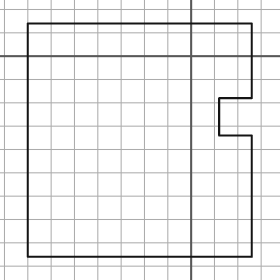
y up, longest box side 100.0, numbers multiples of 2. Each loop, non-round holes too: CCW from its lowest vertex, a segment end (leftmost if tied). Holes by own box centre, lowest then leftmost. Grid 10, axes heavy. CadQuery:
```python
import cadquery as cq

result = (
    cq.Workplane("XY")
    .moveTo(-70.0, -86.0)
    .lineTo(26.0, -86.0)
    .lineTo(26.0, -34.0)
    .lineTo(12.0, -34.0)
    .lineTo(12.0, -18.0)
    .lineTo(26.0, -18.0)
    .lineTo(26.0, 14.0)
    .lineTo(-70.0, 14.0)
    .close()
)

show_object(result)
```